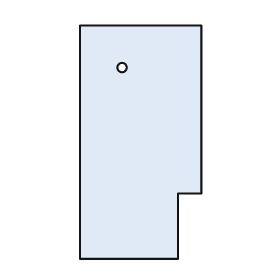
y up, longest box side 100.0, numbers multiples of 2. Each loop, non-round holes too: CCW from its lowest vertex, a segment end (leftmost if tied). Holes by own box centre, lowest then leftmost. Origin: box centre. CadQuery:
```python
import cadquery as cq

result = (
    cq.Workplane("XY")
    .moveTo(-26.0, -50.0)
    .lineTo(16.0, -50.0)
    .lineTo(16.0, -22.0)
    .lineTo(26.0, -22.0)
    .lineTo(26.0, 50.0)
    .lineTo(-26.0, 50.0)
    .close()
    .moveTo(-8.0, 32.0)
    .circle(2.0)
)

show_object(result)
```